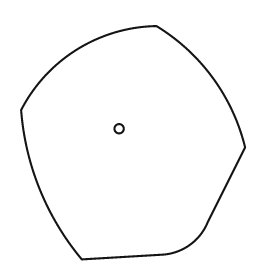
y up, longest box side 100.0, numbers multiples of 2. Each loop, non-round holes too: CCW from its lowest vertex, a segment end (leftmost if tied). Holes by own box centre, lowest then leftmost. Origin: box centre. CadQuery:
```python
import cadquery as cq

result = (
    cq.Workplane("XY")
    .moveTo(-22.0, -50.0)
    .lineTo(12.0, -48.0)
    .threePointArc((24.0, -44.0), (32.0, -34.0))
    .lineTo(48.0, -2.0)
    .threePointArc((34.0, 28.0), (10.0, 50.0))
    .threePointArc((-24.0, 40.0), (-48.0, 14.0))
    .threePointArc((-40.0, -20.0), (-22.0, -50.0))
    .close()
    .moveTo(-6.0, 6.0)
    .circle(2.0)
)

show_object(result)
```